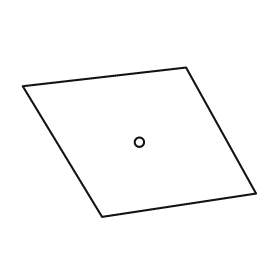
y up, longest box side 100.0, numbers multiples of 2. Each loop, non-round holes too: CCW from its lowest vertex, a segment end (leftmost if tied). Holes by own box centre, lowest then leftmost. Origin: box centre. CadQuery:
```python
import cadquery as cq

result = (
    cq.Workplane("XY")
    .moveTo(-16.0, -32.0)
    .lineTo(50.0, -22.0)
    .lineTo(20.0, 32.0)
    .lineTo(-50.0, 24.0)
    .close()
    .moveTo(0.0, 0.0)
    .circle(2.0)
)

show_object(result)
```